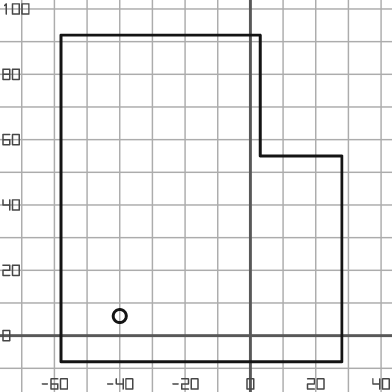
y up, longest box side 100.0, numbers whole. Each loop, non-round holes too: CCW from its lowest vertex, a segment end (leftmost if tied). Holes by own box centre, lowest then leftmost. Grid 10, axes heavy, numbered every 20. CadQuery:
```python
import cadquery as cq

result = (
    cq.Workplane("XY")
    .moveTo(-58.0, -8.0)
    .lineTo(28.0, -8.0)
    .lineTo(28.0, 55.0)
    .lineTo(3.0, 55.0)
    .lineTo(3.0, 92.0)
    .lineTo(-58.0, 92.0)
    .close()
    .moveTo(-40.0, 6.0)
    .circle(2.0)
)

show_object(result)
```